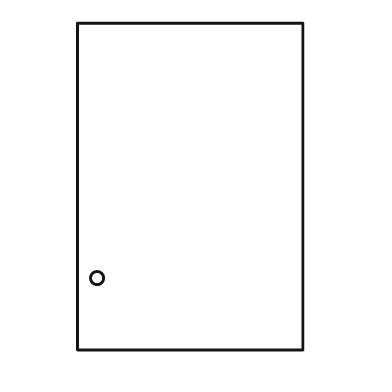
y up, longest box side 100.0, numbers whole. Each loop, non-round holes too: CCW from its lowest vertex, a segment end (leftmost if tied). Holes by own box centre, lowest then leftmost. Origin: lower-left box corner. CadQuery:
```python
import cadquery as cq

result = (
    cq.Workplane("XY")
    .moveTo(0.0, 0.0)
    .lineTo(69.0, 0.0)
    .lineTo(69.0, 100.0)
    .lineTo(0.0, 100.0)
    .close()
    .moveTo(6.0, 22.0)
    .circle(2.0)
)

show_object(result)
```